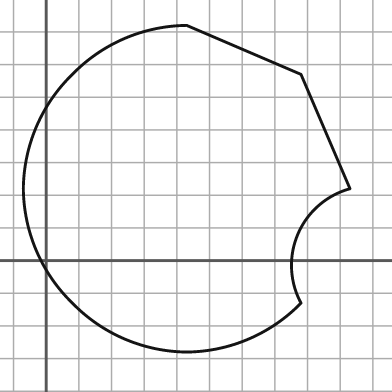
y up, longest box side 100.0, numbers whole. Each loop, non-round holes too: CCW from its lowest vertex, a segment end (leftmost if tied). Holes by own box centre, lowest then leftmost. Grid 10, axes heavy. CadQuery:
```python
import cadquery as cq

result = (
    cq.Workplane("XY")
    .moveTo(43.0, -28.0)
    .threePointArc((62.0, -24.0), (78.0, -13.0))
    .threePointArc((77.0, 8.0), (93.0, 22.0))
    .lineTo(78.0, 57.0)
    .lineTo(43.0, 72.0)
    .threePointArc((24.0, 68.0), (8.0, 57.0))
    .threePointArc((-3.0, 41.0), (-7.0, 22.0))
    .threePointArc((-3.0, 3.0), (8.0, -13.0))
    .threePointArc((24.0, -24.0), (43.0, -28.0))
    .close()
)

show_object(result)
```